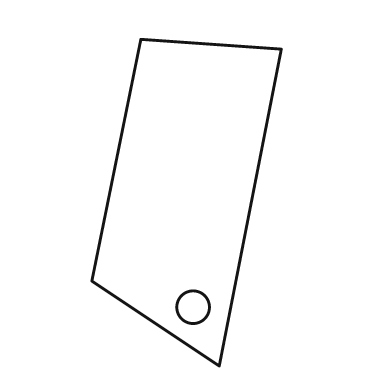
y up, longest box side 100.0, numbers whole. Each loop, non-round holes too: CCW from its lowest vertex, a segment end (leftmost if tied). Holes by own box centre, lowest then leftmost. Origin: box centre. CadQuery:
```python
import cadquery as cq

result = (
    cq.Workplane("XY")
    .moveTo(10.0, -50.0)
    .lineTo(29.0, 47.0)
    .lineTo(-14.0, 50.0)
    .lineTo(-29.0, -24.0)
    .close()
    .moveTo(2.0, -32.0)
    .circle(5.0)
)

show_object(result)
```